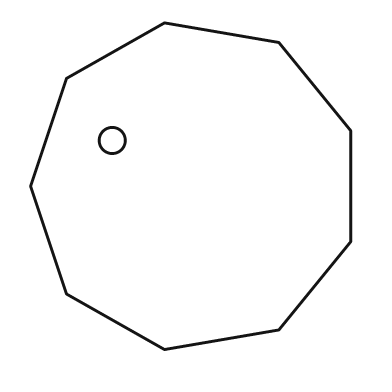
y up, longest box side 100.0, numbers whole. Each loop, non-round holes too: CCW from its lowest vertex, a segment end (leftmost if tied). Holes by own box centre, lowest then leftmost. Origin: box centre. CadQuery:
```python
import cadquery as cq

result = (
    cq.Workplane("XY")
    .moveTo(-8.0, -50.0)
    .lineTo(27.0, -44.0)
    .lineTo(49.0, -17.0)
    .lineTo(49.0, 17.0)
    .lineTo(27.0, 44.0)
    .lineTo(-8.0, 50.0)
    .lineTo(-38.0, 33.0)
    .lineTo(-49.0, 0.0)
    .lineTo(-38.0, -33.0)
    .close()
    .moveTo(-24.0, 14.0)
    .circle(4.0)
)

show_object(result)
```